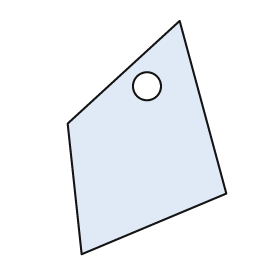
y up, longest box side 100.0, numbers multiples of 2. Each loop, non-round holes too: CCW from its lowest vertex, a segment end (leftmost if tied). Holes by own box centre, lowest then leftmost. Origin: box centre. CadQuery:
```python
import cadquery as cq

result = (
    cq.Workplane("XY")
    .moveTo(-28.0, -50.0)
    .lineTo(34.0, -24.0)
    .lineTo(14.0, 50.0)
    .lineTo(-34.0, 6.0)
    .close()
    .moveTo(0.0, 22.0)
    .circle(6.0)
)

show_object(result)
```